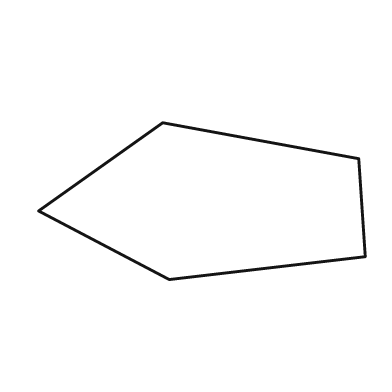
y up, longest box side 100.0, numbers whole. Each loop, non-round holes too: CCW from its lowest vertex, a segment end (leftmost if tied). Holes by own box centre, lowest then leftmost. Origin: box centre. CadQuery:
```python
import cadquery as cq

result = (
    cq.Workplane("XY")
    .moveTo(-10.0, -24.0)
    .lineTo(50.0, -17.0)
    .lineTo(48.0, 13.0)
    .lineTo(-12.0, 24.0)
    .lineTo(-50.0, -3.0)
    .close()
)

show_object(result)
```